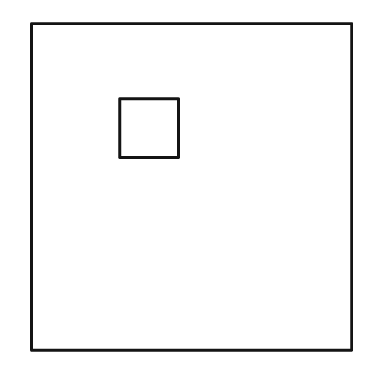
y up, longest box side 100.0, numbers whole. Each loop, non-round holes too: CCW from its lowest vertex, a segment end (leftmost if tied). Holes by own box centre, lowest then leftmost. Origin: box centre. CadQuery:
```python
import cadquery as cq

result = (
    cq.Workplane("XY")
    .moveTo(-49.0, -50.0)
    .lineTo(49.0, -50.0)
    .lineTo(49.0, 50.0)
    .lineTo(-49.0, 50.0)
    .close()
    .moveTo(-22.0, 9.0)
    .lineTo(-4.0, 9.0)
    .lineTo(-4.0, 27.0)
    .lineTo(-22.0, 27.0)
    .close()
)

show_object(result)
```